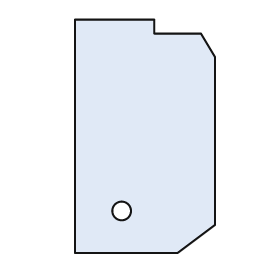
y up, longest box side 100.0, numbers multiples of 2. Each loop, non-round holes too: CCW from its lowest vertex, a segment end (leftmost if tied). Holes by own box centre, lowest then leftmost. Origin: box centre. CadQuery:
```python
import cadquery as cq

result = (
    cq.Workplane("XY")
    .moveTo(-30.0, -50.0)
    .lineTo(14.0, -50.0)
    .lineTo(30.0, -38.0)
    .lineTo(30.0, 34.0)
    .lineTo(24.0, 44.0)
    .lineTo(4.0, 44.0)
    .lineTo(4.0, 50.0)
    .lineTo(-30.0, 50.0)
    .close()
    .moveTo(-10.0, -32.0)
    .circle(4.0)
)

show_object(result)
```